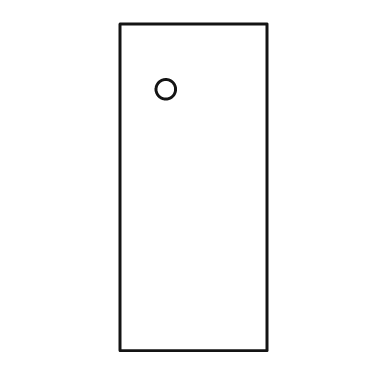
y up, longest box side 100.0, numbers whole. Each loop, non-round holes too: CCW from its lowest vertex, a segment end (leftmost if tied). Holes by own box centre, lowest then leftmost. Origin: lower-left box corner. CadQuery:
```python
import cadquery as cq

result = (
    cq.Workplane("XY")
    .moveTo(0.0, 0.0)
    .lineTo(45.0, 0.0)
    .lineTo(45.0, 100.0)
    .lineTo(0.0, 100.0)
    .close()
    .moveTo(14.0, 80.0)
    .circle(3.0)
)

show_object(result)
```